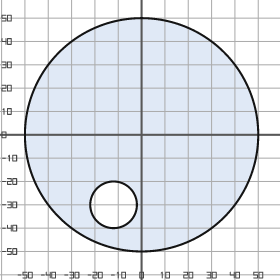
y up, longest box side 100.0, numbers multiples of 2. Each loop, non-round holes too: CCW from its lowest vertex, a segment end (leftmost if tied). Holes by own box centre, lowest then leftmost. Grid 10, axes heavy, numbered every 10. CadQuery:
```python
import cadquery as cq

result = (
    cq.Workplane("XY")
    .moveTo(0.0, 0.0)
    .circle(50.0)
    .moveTo(-12.0, -30.0)
    .circle(10.0)
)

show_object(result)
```